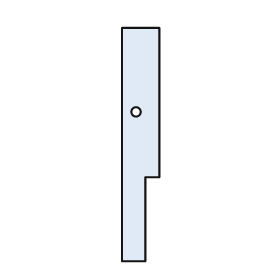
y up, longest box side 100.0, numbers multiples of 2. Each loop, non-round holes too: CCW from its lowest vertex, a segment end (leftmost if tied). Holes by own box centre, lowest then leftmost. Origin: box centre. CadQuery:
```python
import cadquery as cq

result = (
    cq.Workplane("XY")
    .moveTo(-8.0, -50.0)
    .lineTo(2.0, -50.0)
    .lineTo(2.0, -14.0)
    .lineTo(8.0, -14.0)
    .lineTo(8.0, 50.0)
    .lineTo(-8.0, 50.0)
    .close()
    .moveTo(-2.0, 14.0)
    .circle(2.0)
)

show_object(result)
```